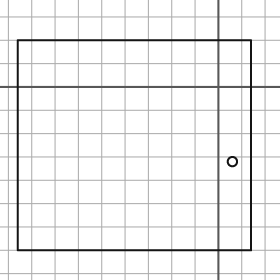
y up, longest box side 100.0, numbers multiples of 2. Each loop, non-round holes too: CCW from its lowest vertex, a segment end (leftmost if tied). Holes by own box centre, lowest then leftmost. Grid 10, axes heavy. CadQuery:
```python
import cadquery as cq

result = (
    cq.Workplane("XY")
    .moveTo(-86.0, -70.0)
    .lineTo(14.0, -70.0)
    .lineTo(14.0, 20.0)
    .lineTo(-86.0, 20.0)
    .close()
    .moveTo(6.0, -32.0)
    .circle(2.0)
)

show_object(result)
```